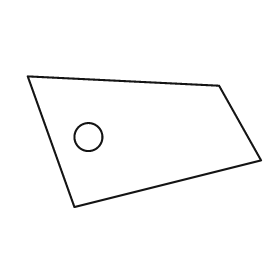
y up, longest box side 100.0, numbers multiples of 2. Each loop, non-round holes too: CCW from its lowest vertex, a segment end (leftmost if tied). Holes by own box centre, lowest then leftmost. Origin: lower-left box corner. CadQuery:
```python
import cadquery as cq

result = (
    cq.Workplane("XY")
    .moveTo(20.0, 0.0)
    .lineTo(100.0, 20.0)
    .lineTo(82.0, 52.0)
    .lineTo(0.0, 56.0)
    .close()
    .moveTo(26.0, 30.0)
    .circle(6.0)
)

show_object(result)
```